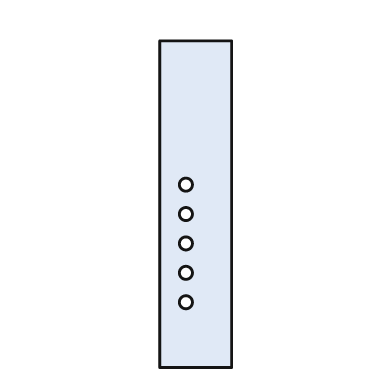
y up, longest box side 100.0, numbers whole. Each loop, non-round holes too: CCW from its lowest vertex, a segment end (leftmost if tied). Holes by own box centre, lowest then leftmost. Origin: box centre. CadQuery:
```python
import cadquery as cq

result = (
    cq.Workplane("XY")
    .moveTo(-11.0, -50.0)
    .lineTo(11.0, -50.0)
    .lineTo(11.0, 50.0)
    .lineTo(-11.0, 50.0)
    .close()
    .moveTo(-3.0, -30.0)
    .circle(2.0)
    .moveTo(-3.0, -21.0)
    .circle(2.0)
    .moveTo(-3.0, -12.0)
    .circle(2.0)
    .moveTo(-3.0, -3.0)
    .circle(2.0)
    .moveTo(-3.0, 6.0)
    .circle(2.0)
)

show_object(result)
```